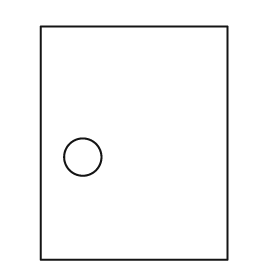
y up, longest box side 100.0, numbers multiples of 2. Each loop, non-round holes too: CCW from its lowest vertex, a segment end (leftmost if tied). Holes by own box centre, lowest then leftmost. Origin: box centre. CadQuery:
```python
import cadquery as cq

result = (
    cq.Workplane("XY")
    .moveTo(-40.0, -50.0)
    .lineTo(40.0, -50.0)
    .lineTo(40.0, 50.0)
    .lineTo(-40.0, 50.0)
    .close()
    .moveTo(-22.0, -6.0)
    .circle(8.0)
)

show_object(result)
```